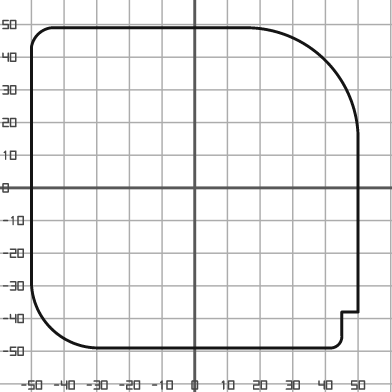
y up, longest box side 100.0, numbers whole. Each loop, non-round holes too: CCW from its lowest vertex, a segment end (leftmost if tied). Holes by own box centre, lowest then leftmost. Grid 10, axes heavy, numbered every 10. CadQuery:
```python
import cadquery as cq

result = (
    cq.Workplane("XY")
    .moveTo(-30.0, -49.0)
    .lineTo(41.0, -49.0)
    .threePointArc((44.0, -48.0), (45.0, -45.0))
    .lineTo(45.0, -38.0)
    .lineTo(50.0, -38.0)
    .lineTo(50.0, 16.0)
    .threePointArc((40.0, 39.0), (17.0, 49.0))
    .lineTo(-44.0, 49.0)
    .threePointArc((-48.0, 47.0), (-50.0, 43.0))
    .lineTo(-50.0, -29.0)
    .threePointArc((-44.0, -43.0), (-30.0, -49.0))
    .close()
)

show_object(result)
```